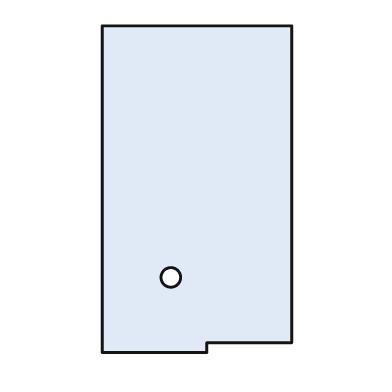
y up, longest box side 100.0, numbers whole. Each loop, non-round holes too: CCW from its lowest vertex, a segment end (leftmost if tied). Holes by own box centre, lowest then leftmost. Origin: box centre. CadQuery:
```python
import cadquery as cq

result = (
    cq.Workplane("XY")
    .moveTo(-29.0, -50.0)
    .lineTo(3.0, -50.0)
    .lineTo(3.0, -47.0)
    .lineTo(29.0, -47.0)
    .lineTo(29.0, 50.0)
    .lineTo(-29.0, 50.0)
    .close()
    .moveTo(-8.0, -27.0)
    .circle(3.0)
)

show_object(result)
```